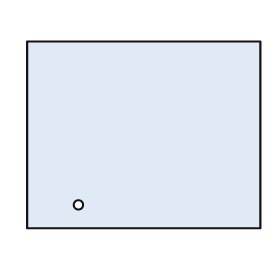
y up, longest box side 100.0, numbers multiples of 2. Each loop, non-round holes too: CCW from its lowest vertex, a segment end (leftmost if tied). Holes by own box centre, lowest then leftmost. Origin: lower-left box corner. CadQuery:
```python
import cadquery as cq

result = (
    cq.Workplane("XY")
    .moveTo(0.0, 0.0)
    .lineTo(100.0, 0.0)
    .lineTo(100.0, 80.0)
    .lineTo(0.0, 80.0)
    .close()
    .moveTo(22.0, 10.0)
    .circle(2.0)
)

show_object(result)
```